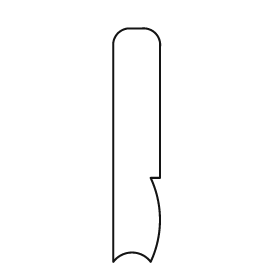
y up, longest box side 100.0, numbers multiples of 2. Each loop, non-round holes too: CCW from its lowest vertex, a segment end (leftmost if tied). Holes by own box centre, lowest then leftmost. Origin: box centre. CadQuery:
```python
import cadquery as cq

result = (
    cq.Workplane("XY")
    .moveTo(-10.0, -50.0)
    .threePointArc((-2.0, -46.0), (6.0, -50.0))
    .threePointArc((10.0, -32.0), (6.0, -14.0))
    .lineTo(10.0, -14.0)
    .lineTo(10.0, 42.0)
    .threePointArc((8.0, 48.0), (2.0, 50.0))
    .lineTo(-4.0, 50.0)
    .threePointArc((-8.0, 48.0), (-10.0, 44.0))
    .close()
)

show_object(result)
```